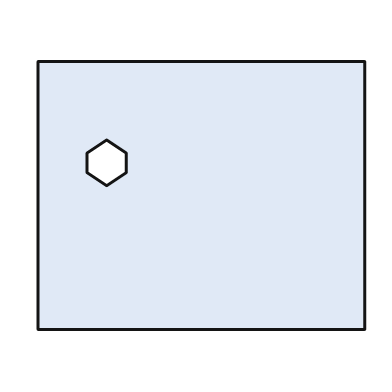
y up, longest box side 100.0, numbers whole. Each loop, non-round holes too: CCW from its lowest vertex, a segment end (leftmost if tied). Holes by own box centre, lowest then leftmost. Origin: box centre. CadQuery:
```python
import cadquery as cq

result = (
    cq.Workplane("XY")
    .moveTo(-50.0, -41.0)
    .lineTo(50.0, -41.0)
    .lineTo(50.0, 41.0)
    .lineTo(-50.0, 41.0)
    .close()
    .moveTo(-29.0, 3.0)
    .lineTo(-23.0, 7.0)
    .lineTo(-23.0, 13.0)
    .lineTo(-29.0, 17.0)
    .lineTo(-35.0, 13.0)
    .lineTo(-35.0, 7.0)
    .close()
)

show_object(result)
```